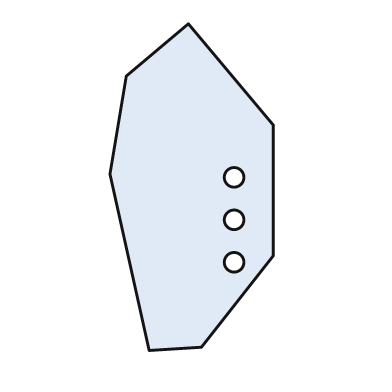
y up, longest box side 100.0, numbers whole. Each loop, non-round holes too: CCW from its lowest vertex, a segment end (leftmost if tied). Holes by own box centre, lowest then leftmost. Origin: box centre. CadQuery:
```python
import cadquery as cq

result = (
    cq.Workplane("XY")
    .moveTo(-13.0, -50.0)
    .lineTo(3.0, -49.0)
    .lineTo(25.0, -21.0)
    .lineTo(25.0, 19.0)
    .lineTo(-1.0, 50.0)
    .lineTo(-20.0, 34.0)
    .lineTo(-25.0, 4.0)
    .close()
    .moveTo(13.0, -23.0)
    .circle(3.0)
    .moveTo(13.0, -10.0)
    .circle(3.0)
    .moveTo(13.0, 3.0)
    .circle(3.0)
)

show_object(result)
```